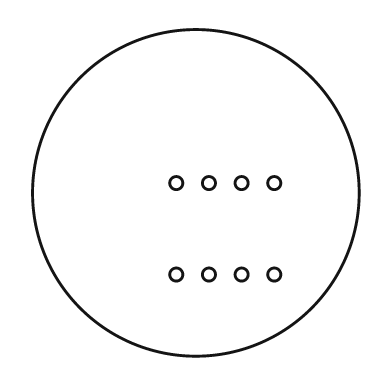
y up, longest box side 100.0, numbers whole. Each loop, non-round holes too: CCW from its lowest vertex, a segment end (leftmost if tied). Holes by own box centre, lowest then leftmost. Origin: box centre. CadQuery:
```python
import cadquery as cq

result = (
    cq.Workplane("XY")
    .moveTo(0.0, 0.0)
    .circle(50.0)
    .moveTo(-6.0, -25.0)
    .circle(2.0)
    .moveTo(4.0, -25.0)
    .circle(2.0)
    .moveTo(14.0, -25.0)
    .circle(2.0)
    .moveTo(24.0, -25.0)
    .circle(2.0)
    .moveTo(-6.0, 3.0)
    .circle(2.0)
    .moveTo(4.0, 3.0)
    .circle(2.0)
    .moveTo(14.0, 3.0)
    .circle(2.0)
    .moveTo(24.0, 3.0)
    .circle(2.0)
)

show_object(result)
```